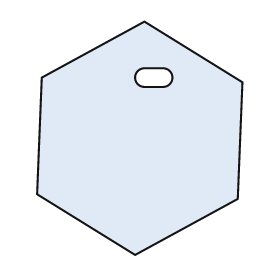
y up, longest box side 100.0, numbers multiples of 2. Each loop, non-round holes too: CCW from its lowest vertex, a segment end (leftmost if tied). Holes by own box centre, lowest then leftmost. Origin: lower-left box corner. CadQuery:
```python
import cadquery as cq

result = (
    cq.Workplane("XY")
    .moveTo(42.0, 0.0)
    .lineTo(86.0, 24.0)
    .lineTo(88.0, 74.0)
    .lineTo(46.0, 100.0)
    .lineTo(2.0, 76.0)
    .lineTo(0.0, 26.0)
    .close()
    .moveTo(46.0, 72.0)
    .lineTo(54.0, 72.0)
    .threePointArc((58.0, 76.0), (54.0, 80.0))
    .lineTo(46.0, 80.0)
    .threePointArc((42.0, 76.0), (46.0, 72.0))
    .close()
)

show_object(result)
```